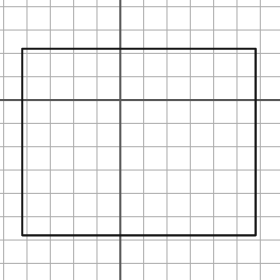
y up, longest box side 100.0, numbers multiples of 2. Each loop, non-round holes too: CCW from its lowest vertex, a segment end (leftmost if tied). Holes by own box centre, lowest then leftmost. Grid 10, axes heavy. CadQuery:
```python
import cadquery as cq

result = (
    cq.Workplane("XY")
    .moveTo(-42.0, -58.0)
    .lineTo(58.0, -58.0)
    .lineTo(58.0, 22.0)
    .lineTo(-42.0, 22.0)
    .close()
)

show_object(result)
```